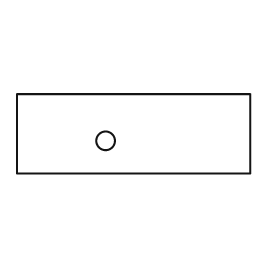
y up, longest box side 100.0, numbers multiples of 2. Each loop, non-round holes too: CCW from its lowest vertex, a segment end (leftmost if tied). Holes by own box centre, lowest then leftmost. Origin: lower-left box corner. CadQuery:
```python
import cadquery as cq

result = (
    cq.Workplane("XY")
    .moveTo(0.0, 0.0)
    .lineTo(100.0, 0.0)
    .lineTo(100.0, 34.0)
    .lineTo(0.0, 34.0)
    .close()
    .moveTo(38.0, 14.0)
    .circle(4.0)
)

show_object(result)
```